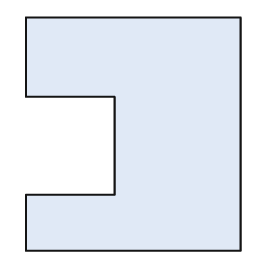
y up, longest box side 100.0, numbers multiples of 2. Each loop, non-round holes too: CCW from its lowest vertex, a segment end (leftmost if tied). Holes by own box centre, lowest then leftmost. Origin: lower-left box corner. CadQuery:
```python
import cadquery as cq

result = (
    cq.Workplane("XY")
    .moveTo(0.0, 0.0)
    .lineTo(92.0, 0.0)
    .lineTo(92.0, 100.0)
    .lineTo(0.0, 100.0)
    .lineTo(0.0, 66.0)
    .lineTo(38.0, 66.0)
    .lineTo(38.0, 24.0)
    .lineTo(0.0, 24.0)
    .close()
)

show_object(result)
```